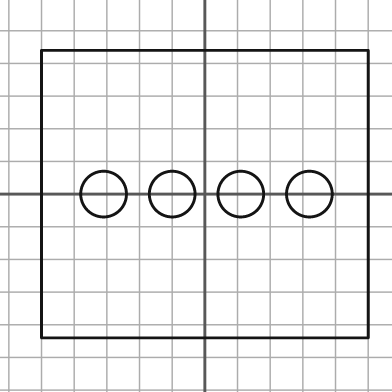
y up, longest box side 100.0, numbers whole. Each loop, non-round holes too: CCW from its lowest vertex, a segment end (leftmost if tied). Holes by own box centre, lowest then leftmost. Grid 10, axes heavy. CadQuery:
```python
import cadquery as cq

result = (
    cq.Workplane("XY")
    .moveTo(-50.0, -44.0)
    .lineTo(50.0, -44.0)
    .lineTo(50.0, 44.0)
    .lineTo(-50.0, 44.0)
    .close()
    .moveTo(-31.0, 0.0)
    .circle(7.0)
    .moveTo(-10.0, 0.0)
    .circle(7.0)
    .moveTo(11.0, 0.0)
    .circle(7.0)
    .moveTo(32.0, 0.0)
    .circle(7.0)
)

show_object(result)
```